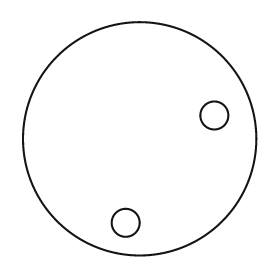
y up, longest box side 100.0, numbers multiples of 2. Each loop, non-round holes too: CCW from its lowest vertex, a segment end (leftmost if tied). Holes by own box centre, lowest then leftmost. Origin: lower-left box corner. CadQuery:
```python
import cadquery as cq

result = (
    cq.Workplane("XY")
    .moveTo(50.0, 50.0)
    .circle(50.0)
    .moveTo(44.0, 14.0)
    .circle(6.0)
    .moveTo(82.0, 60.0)
    .circle(6.0)
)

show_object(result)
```